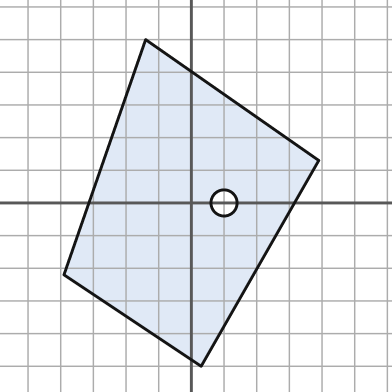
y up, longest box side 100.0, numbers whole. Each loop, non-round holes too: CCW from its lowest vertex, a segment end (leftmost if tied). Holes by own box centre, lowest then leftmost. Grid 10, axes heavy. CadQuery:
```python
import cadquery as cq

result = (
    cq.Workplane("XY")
    .moveTo(3.0, -50.0)
    .lineTo(39.0, 13.0)
    .lineTo(-14.0, 50.0)
    .lineTo(-39.0, -22.0)
    .close()
    .moveTo(10.0, 0.0)
    .circle(4.0)
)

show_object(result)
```